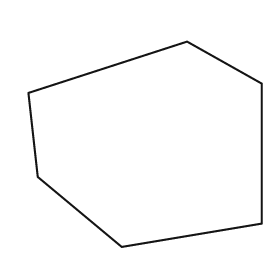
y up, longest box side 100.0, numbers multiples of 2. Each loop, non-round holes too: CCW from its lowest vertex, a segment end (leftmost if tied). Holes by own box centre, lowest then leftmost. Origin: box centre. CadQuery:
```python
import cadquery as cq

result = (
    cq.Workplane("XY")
    .moveTo(-10.0, -44.0)
    .lineTo(50.0, -34.0)
    .lineTo(50.0, 26.0)
    .lineTo(18.0, 44.0)
    .lineTo(-50.0, 22.0)
    .lineTo(-46.0, -14.0)
    .close()
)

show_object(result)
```